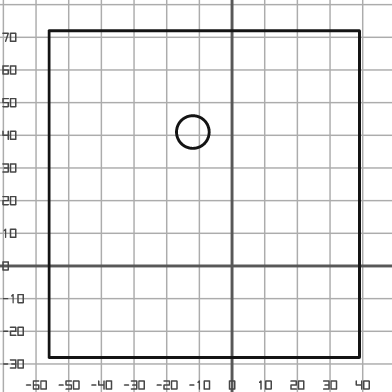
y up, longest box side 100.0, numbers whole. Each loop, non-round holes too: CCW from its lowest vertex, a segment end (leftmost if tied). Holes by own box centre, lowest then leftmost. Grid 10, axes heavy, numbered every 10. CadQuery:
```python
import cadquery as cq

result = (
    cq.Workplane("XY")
    .moveTo(-56.0, -28.0)
    .lineTo(39.0, -28.0)
    .lineTo(39.0, 72.0)
    .lineTo(-56.0, 72.0)
    .close()
    .moveTo(-12.0, 41.0)
    .circle(5.0)
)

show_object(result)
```